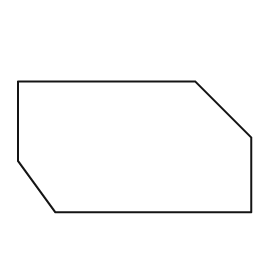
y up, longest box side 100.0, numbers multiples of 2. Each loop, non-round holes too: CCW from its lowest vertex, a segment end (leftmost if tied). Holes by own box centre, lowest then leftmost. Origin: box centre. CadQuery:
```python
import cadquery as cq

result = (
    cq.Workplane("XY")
    .moveTo(-34.0, -28.0)
    .lineTo(50.0, -28.0)
    .lineTo(50.0, 4.0)
    .lineTo(26.0, 28.0)
    .lineTo(-50.0, 28.0)
    .lineTo(-50.0, -6.0)
    .close()
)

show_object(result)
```